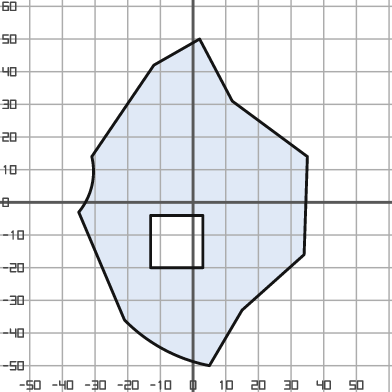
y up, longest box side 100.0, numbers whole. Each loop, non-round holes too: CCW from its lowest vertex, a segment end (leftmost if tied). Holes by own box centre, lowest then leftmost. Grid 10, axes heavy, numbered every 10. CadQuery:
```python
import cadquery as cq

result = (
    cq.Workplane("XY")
    .moveTo(5.0, -50.0)
    .lineTo(15.0, -33.0)
    .lineTo(34.0, -16.0)
    .lineTo(35.0, 14.0)
    .lineTo(12.0, 31.0)
    .lineTo(2.0, 50.0)
    .lineTo(-12.0, 42.0)
    .lineTo(-31.0, 14.0)
    .threePointArc((-31.0, 5.0), (-35.0, -3.0))
    .lineTo(-21.0, -36.0)
    .threePointArc((-9.0, -45.0), (5.0, -50.0))
    .close()
    .moveTo(-13.0, -20.0)
    .lineTo(3.0, -20.0)
    .lineTo(3.0, -4.0)
    .lineTo(-13.0, -4.0)
    .close()
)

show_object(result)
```